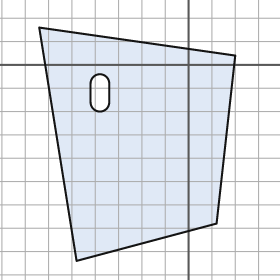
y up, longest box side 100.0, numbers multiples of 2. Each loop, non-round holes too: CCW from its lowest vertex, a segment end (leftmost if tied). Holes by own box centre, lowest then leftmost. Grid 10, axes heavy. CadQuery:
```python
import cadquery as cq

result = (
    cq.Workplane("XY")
    .moveTo(-48.0, -84.0)
    .lineTo(12.0, -68.0)
    .lineTo(20.0, 4.0)
    .lineTo(-64.0, 16.0)
    .close()
    .moveTo(-42.0, -16.0)
    .threePointArc((-38.0, -20.0), (-34.0, -16.0))
    .lineTo(-34.0, -8.0)
    .threePointArc((-38.0, -4.0), (-42.0, -8.0))
    .close()
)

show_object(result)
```